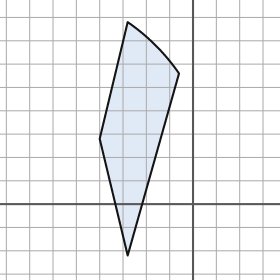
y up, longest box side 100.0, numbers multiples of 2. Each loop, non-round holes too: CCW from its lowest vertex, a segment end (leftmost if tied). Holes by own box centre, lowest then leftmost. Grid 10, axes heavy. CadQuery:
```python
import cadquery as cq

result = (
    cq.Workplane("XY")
    .moveTo(-28.0, -22.0)
    .lineTo(-6.0, 56.0)
    .threePointArc((-16.0, 68.0), (-28.0, 78.0))
    .lineTo(-40.0, 28.0)
    .close()
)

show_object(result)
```